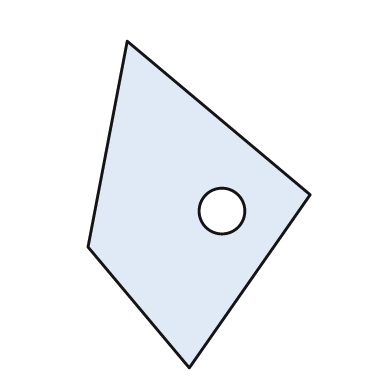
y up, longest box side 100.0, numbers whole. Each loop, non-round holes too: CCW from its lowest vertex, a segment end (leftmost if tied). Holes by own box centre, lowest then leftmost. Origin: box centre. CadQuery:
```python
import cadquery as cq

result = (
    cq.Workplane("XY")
    .moveTo(-3.0, -50.0)
    .lineTo(34.0, 3.0)
    .lineTo(-22.0, 50.0)
    .lineTo(-34.0, -13.0)
    .close()
    .moveTo(7.0, -2.0)
    .circle(7.0)
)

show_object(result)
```